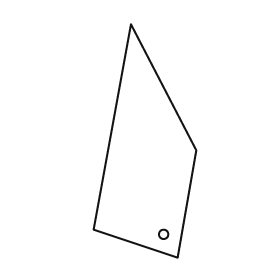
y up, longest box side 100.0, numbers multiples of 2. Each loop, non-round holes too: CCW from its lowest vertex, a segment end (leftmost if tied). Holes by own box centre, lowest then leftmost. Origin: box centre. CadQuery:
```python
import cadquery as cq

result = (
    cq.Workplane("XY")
    .moveTo(14.0, -50.0)
    .lineTo(22.0, -4.0)
    .lineTo(-6.0, 50.0)
    .lineTo(-22.0, -38.0)
    .close()
    .moveTo(8.0, -40.0)
    .circle(2.0)
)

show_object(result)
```